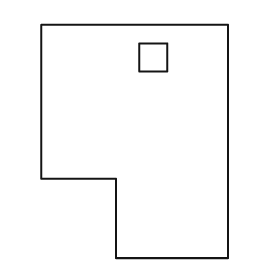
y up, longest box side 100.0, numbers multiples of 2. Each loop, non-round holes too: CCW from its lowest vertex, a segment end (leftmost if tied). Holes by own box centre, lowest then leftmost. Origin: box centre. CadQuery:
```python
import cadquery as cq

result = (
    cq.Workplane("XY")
    .moveTo(-8.0, -50.0)
    .lineTo(40.0, -50.0)
    .lineTo(40.0, 50.0)
    .lineTo(-40.0, 50.0)
    .lineTo(-40.0, -16.0)
    .lineTo(-8.0, -16.0)
    .close()
    .moveTo(2.0, 30.0)
    .lineTo(14.0, 30.0)
    .lineTo(14.0, 42.0)
    .lineTo(2.0, 42.0)
    .close()
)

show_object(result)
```